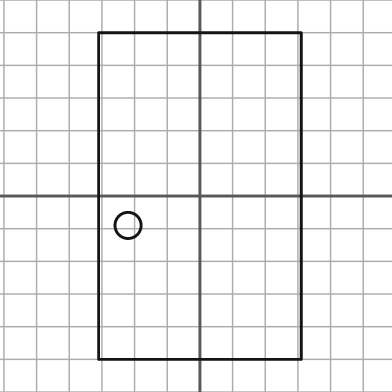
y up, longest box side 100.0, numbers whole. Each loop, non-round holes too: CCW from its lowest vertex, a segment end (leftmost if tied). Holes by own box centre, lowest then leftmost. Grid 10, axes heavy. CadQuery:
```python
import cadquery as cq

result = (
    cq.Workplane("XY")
    .moveTo(-31.0, -50.0)
    .lineTo(31.0, -50.0)
    .lineTo(31.0, 50.0)
    .lineTo(-31.0, 50.0)
    .close()
    .moveTo(-22.0, -9.0)
    .circle(4.0)
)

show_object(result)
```